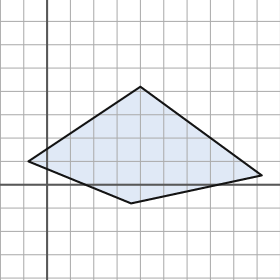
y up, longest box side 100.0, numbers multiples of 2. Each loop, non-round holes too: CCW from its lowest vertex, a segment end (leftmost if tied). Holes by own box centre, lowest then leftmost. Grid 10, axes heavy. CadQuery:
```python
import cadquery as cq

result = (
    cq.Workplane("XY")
    .moveTo(36.0, -8.0)
    .lineTo(92.0, 4.0)
    .lineTo(40.0, 42.0)
    .lineTo(-8.0, 10.0)
    .close()
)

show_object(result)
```